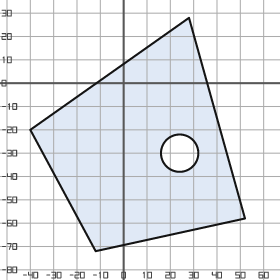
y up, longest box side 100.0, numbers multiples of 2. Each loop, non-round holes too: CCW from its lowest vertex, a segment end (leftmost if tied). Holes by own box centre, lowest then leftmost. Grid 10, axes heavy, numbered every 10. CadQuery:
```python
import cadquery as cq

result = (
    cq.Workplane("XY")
    .moveTo(-12.0, -72.0)
    .lineTo(52.0, -58.0)
    .lineTo(28.0, 28.0)
    .lineTo(-40.0, -20.0)
    .close()
    .moveTo(24.0, -30.0)
    .circle(8.0)
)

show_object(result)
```